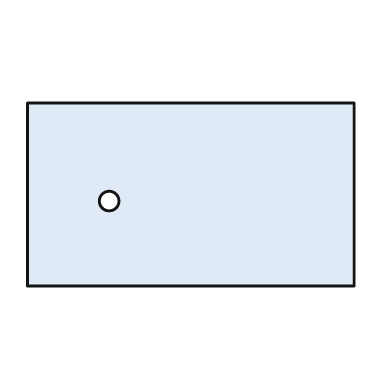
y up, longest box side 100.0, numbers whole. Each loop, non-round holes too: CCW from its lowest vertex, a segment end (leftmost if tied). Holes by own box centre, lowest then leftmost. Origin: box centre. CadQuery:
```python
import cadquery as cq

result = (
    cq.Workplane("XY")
    .moveTo(-50.0, -28.0)
    .lineTo(50.0, -28.0)
    .lineTo(50.0, 28.0)
    .lineTo(-50.0, 28.0)
    .close()
    .moveTo(-25.0, -2.0)
    .circle(3.0)
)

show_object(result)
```